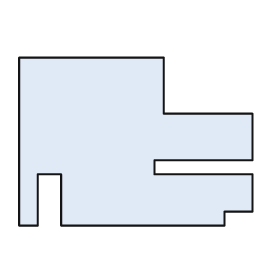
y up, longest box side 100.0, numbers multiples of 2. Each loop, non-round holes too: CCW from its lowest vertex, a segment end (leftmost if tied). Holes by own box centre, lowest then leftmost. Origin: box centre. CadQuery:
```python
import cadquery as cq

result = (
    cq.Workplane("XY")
    .moveTo(-50.0, -36.0)
    .lineTo(-42.0, -36.0)
    .lineTo(-42.0, -14.0)
    .lineTo(-32.0, -14.0)
    .lineTo(-32.0, -36.0)
    .lineTo(38.0, -36.0)
    .lineTo(38.0, -30.0)
    .lineTo(50.0, -30.0)
    .lineTo(50.0, -14.0)
    .lineTo(8.0, -14.0)
    .lineTo(8.0, -8.0)
    .lineTo(50.0, -8.0)
    .lineTo(50.0, 12.0)
    .lineTo(12.0, 12.0)
    .lineTo(12.0, 36.0)
    .lineTo(-50.0, 36.0)
    .close()
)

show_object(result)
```